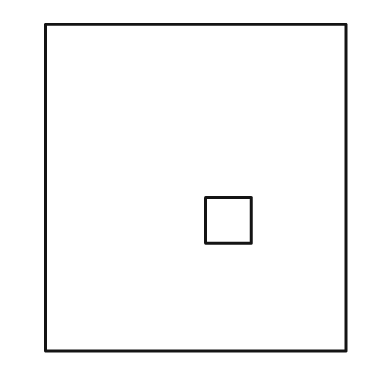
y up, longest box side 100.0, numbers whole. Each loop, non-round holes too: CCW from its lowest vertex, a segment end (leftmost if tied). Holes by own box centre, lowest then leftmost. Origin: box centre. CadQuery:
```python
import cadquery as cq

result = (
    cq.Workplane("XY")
    .moveTo(-46.0, -50.0)
    .lineTo(46.0, -50.0)
    .lineTo(46.0, 50.0)
    .lineTo(-46.0, 50.0)
    .close()
    .moveTo(3.0, -17.0)
    .lineTo(17.0, -17.0)
    .lineTo(17.0, -3.0)
    .lineTo(3.0, -3.0)
    .close()
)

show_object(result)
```